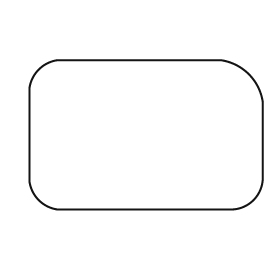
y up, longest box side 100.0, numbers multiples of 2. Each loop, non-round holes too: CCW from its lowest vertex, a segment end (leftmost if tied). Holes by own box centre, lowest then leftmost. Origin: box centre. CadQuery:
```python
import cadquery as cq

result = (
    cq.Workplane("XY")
    .moveTo(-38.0, -32.0)
    .lineTo(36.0, -32.0)
    .threePointArc((46.0, -28.0), (50.0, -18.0))
    .lineTo(50.0, 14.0)
    .threePointArc((44.0, 26.0), (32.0, 32.0))
    .lineTo(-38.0, 32.0)
    .threePointArc((-46.0, 28.0), (-50.0, 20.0))
    .lineTo(-50.0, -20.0)
    .threePointArc((-46.0, -28.0), (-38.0, -32.0))
    .close()
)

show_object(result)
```